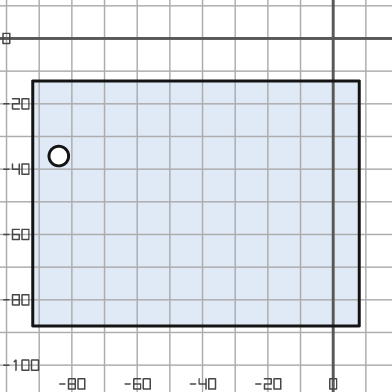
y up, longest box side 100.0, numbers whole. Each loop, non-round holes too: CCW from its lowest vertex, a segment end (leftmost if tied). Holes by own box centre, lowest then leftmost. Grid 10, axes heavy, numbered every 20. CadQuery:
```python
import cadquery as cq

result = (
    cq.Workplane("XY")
    .moveTo(-92.0, -88.0)
    .lineTo(8.0, -88.0)
    .lineTo(8.0, -13.0)
    .lineTo(-92.0, -13.0)
    .close()
    .moveTo(-84.0, -36.0)
    .circle(3.0)
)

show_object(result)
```